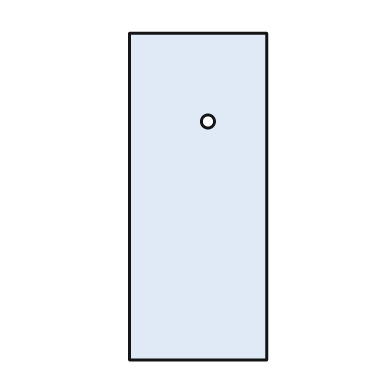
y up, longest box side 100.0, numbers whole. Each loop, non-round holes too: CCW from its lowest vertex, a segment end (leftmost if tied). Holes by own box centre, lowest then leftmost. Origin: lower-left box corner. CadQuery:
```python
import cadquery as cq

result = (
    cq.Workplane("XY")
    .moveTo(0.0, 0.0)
    .lineTo(42.0, 0.0)
    .lineTo(42.0, 100.0)
    .lineTo(0.0, 100.0)
    .close()
    .moveTo(24.0, 73.0)
    .circle(2.0)
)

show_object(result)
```